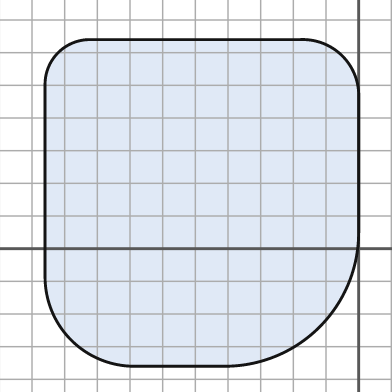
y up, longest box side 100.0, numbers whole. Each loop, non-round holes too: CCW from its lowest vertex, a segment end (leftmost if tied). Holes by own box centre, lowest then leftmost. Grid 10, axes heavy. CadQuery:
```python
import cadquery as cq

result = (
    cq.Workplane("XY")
    .moveTo(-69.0, -36.0)
    .lineTo(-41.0, -36.0)
    .threePointArc((-12.0, -24.0), (0.0, 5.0))
    .lineTo(0.0, 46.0)
    .threePointArc((-5.0, 59.0), (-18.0, 64.0))
    .lineTo(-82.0, 64.0)
    .threePointArc((-92.0, 60.0), (-96.0, 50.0))
    .lineTo(-96.0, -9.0)
    .threePointArc((-88.0, -28.0), (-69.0, -36.0))
    .close()
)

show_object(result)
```